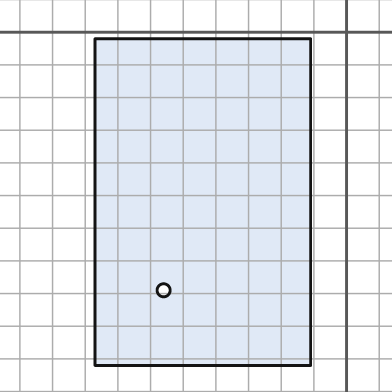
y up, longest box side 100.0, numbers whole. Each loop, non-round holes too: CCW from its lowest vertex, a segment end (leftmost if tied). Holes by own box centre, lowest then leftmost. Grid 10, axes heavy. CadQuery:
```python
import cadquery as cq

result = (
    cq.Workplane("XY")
    .moveTo(-77.0, -102.0)
    .lineTo(-11.0, -102.0)
    .lineTo(-11.0, -2.0)
    .lineTo(-77.0, -2.0)
    .close()
    .moveTo(-56.0, -79.0)
    .circle(2.0)
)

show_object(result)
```